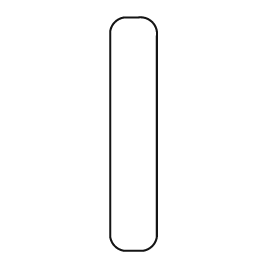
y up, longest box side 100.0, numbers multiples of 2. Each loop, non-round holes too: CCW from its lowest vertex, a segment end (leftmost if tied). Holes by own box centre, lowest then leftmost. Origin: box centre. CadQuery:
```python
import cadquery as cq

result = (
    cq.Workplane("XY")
    .moveTo(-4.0, -50.0)
    .lineTo(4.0, -50.0)
    .threePointArc((8.0, -48.0), (10.0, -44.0))
    .lineTo(10.0, 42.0)
    .threePointArc((8.0, 48.0), (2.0, 50.0))
    .lineTo(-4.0, 50.0)
    .threePointArc((-8.0, 48.0), (-10.0, 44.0))
    .lineTo(-10.0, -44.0)
    .threePointArc((-8.0, -48.0), (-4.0, -50.0))
    .close()
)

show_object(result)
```